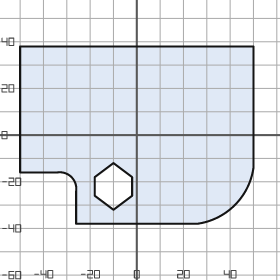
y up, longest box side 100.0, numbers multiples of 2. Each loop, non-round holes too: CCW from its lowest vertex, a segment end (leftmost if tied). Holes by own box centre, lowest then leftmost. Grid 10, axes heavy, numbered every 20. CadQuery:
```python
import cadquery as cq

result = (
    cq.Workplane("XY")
    .moveTo(-26.0, -38.0)
    .lineTo(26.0, -38.0)
    .threePointArc((42.0, -30.0), (50.0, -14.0))
    .lineTo(50.0, 38.0)
    .lineTo(-50.0, 38.0)
    .lineTo(-50.0, -16.0)
    .lineTo(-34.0, -16.0)
    .threePointArc((-28.0, -18.0), (-26.0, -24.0))
    .close()
    .moveTo(-10.0, -32.0)
    .lineTo(-2.0, -26.0)
    .lineTo(-2.0, -18.0)
    .lineTo(-10.0, -12.0)
    .lineTo(-18.0, -18.0)
    .lineTo(-18.0, -26.0)
    .close()
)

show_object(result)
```